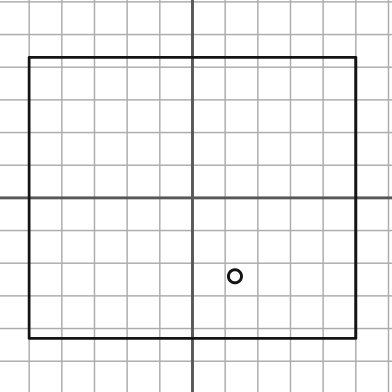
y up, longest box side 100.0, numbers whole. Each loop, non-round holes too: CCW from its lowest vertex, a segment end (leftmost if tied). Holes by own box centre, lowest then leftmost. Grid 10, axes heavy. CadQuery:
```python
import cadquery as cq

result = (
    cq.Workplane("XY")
    .moveTo(-50.0, -43.0)
    .lineTo(50.0, -43.0)
    .lineTo(50.0, 43.0)
    .lineTo(-50.0, 43.0)
    .close()
    .moveTo(13.0, -24.0)
    .circle(2.0)
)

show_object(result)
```